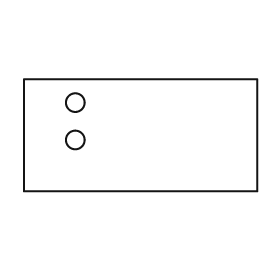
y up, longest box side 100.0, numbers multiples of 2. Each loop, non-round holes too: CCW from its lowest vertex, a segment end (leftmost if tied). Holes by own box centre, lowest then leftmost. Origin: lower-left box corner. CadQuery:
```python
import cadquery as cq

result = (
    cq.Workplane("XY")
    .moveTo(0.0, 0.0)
    .lineTo(100.0, 0.0)
    .lineTo(100.0, 48.0)
    .lineTo(0.0, 48.0)
    .close()
    .moveTo(22.0, 22.0)
    .circle(4.0)
    .moveTo(22.0, 38.0)
    .circle(4.0)
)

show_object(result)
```